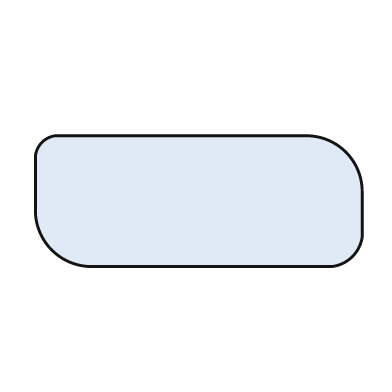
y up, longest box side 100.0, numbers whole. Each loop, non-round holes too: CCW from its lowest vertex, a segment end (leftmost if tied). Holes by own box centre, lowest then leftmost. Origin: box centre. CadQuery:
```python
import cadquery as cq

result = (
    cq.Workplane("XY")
    .moveTo(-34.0, -20.0)
    .lineTo(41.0, -20.0)
    .threePointArc((47.0, -17.0), (50.0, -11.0))
    .lineTo(50.0, 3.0)
    .threePointArc((45.0, 15.0), (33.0, 20.0))
    .lineTo(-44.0, 20.0)
    .threePointArc((-48.0, 18.0), (-50.0, 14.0))
    .lineTo(-50.0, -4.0)
    .threePointArc((-45.0, -15.0), (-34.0, -20.0))
    .close()
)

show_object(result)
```